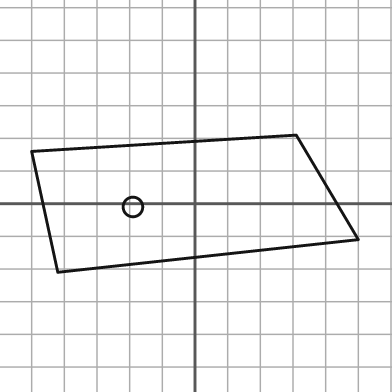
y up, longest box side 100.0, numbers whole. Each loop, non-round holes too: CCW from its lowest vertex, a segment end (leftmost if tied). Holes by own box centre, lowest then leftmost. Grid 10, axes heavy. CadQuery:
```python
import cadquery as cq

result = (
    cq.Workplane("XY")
    .moveTo(-42.0, -21.0)
    .lineTo(50.0, -11.0)
    .lineTo(31.0, 21.0)
    .lineTo(-50.0, 16.0)
    .close()
    .moveTo(-19.0, -1.0)
    .circle(3.0)
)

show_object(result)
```